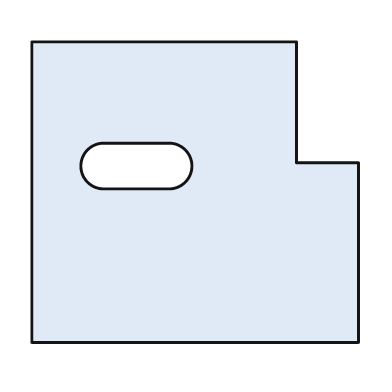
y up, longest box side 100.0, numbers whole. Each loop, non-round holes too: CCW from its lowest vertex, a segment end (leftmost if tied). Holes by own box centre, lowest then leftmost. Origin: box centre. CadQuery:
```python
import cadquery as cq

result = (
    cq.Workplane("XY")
    .moveTo(-50.0, -46.0)
    .lineTo(50.0, -46.0)
    .lineTo(50.0, 9.0)
    .lineTo(31.0, 9.0)
    .lineTo(31.0, 46.0)
    .lineTo(-50.0, 46.0)
    .close()
    .moveTo(-28.0, 1.0)
    .lineTo(-8.0, 1.0)
    .threePointArc((-1.0, 8.0), (-8.0, 15.0))
    .lineTo(-28.0, 15.0)
    .threePointArc((-35.0, 8.0), (-28.0, 1.0))
    .close()
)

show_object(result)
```